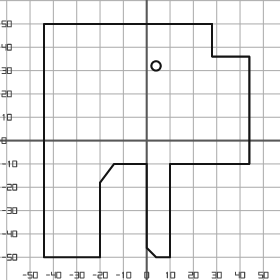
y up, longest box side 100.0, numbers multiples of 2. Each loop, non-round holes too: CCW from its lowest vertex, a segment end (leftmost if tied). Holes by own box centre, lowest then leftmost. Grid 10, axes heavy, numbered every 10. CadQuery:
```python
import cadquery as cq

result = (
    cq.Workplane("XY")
    .moveTo(-44.0, -50.0)
    .lineTo(-20.0, -50.0)
    .lineTo(-20.0, -18.0)
    .lineTo(-14.0, -10.0)
    .lineTo(0.0, -10.0)
    .lineTo(0.0, -46.0)
    .lineTo(4.0, -50.0)
    .lineTo(10.0, -50.0)
    .lineTo(10.0, -10.0)
    .lineTo(44.0, -10.0)
    .lineTo(44.0, 36.0)
    .lineTo(28.0, 36.0)
    .lineTo(28.0, 50.0)
    .lineTo(-44.0, 50.0)
    .close()
    .moveTo(4.0, 32.0)
    .circle(2.0)
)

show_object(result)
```